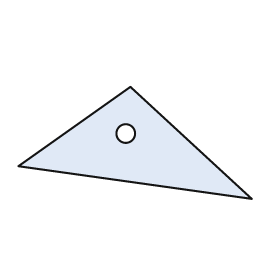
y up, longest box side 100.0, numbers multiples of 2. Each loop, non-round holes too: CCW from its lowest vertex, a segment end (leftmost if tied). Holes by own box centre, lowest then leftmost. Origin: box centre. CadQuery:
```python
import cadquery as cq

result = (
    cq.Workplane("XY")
    .moveTo(50.0, -24.0)
    .lineTo(-2.0, 24.0)
    .lineTo(-50.0, -10.0)
    .close()
    .moveTo(-4.0, 4.0)
    .circle(4.0)
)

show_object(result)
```